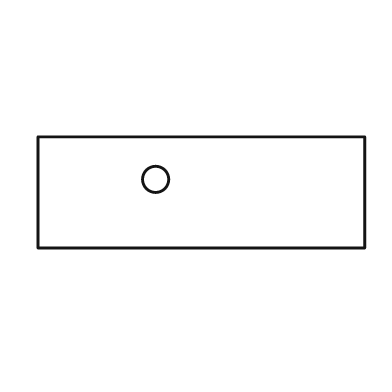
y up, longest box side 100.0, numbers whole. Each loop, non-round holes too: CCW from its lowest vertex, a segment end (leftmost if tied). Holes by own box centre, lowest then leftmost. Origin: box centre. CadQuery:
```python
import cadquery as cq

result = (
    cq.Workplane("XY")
    .moveTo(-50.0, -17.0)
    .lineTo(50.0, -17.0)
    .lineTo(50.0, 17.0)
    .lineTo(-50.0, 17.0)
    .close()
    .moveTo(-14.0, 4.0)
    .circle(4.0)
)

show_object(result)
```